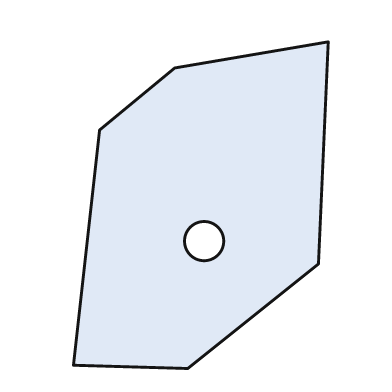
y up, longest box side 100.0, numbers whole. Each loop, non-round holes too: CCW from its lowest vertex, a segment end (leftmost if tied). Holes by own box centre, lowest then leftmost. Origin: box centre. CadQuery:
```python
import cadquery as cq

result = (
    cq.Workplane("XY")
    .moveTo(-4.0, -50.0)
    .lineTo(36.0, -18.0)
    .lineTo(39.0, 50.0)
    .lineTo(-8.0, 42.0)
    .lineTo(-31.0, 23.0)
    .lineTo(-39.0, -49.0)
    .close()
    .moveTo(1.0, -11.0)
    .circle(6.0)
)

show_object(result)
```